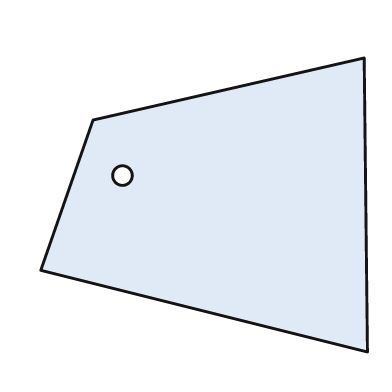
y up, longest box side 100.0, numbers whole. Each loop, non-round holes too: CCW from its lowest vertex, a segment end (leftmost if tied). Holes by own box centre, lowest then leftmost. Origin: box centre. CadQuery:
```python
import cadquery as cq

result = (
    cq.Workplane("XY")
    .moveTo(50.0, -45.0)
    .lineTo(49.0, 45.0)
    .lineTo(-34.0, 26.0)
    .lineTo(-50.0, -20.0)
    .close()
    .moveTo(-25.0, 9.0)
    .circle(3.0)
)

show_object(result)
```